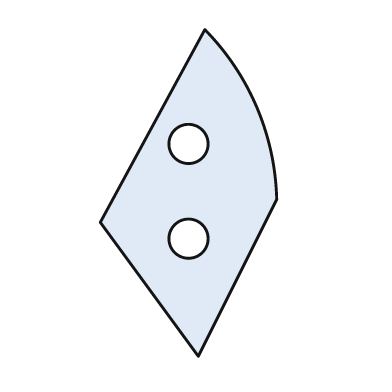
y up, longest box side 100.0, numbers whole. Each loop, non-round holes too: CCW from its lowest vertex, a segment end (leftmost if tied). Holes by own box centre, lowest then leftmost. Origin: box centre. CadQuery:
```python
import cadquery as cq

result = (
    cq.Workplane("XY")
    .moveTo(3.0, -50.0)
    .lineTo(27.0, -2.0)
    .threePointArc((21.0, 26.0), (5.0, 50.0))
    .lineTo(-27.0, -9.0)
    .close()
    .moveTo(0.0, -14.0)
    .circle(6.0)
    .moveTo(0.0, 15.0)
    .circle(6.0)
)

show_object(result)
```